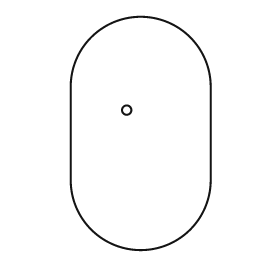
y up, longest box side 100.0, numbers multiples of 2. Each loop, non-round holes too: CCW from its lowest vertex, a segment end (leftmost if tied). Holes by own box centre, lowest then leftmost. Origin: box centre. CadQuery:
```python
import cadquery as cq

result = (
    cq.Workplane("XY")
    .moveTo(-30.0, -20.0)
    .threePointArc((0.0, -50.0), (30.0, -20.0))
    .lineTo(30.0, 20.0)
    .threePointArc((0.0, 50.0), (-30.0, 20.0))
    .close()
    .moveTo(-6.0, 10.0)
    .circle(2.0)
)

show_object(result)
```